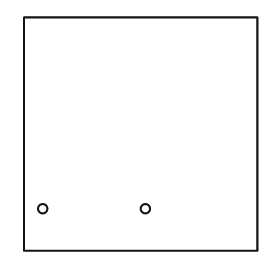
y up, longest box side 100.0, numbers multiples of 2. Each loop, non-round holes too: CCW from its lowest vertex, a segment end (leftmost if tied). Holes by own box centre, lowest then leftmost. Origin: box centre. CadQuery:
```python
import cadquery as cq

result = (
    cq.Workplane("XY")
    .moveTo(-50.0, -50.0)
    .lineTo(50.0, -50.0)
    .lineTo(50.0, 50.0)
    .lineTo(-50.0, 50.0)
    .close()
    .moveTo(-42.0, -32.0)
    .circle(2.0)
    .moveTo(2.0, -32.0)
    .circle(2.0)
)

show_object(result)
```